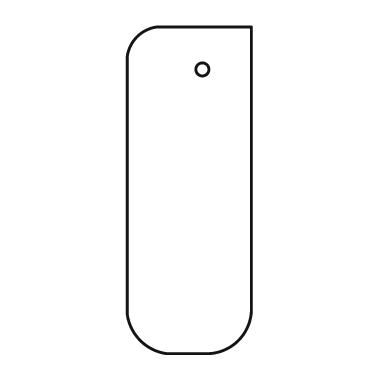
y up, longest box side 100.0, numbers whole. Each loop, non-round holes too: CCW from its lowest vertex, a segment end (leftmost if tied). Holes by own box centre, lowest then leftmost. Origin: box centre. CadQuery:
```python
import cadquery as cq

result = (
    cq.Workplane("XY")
    .moveTo(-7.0, -50.0)
    .lineTo(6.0, -50.0)
    .threePointArc((15.0, -46.0), (19.0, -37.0))
    .lineTo(19.0, 50.0)
    .lineTo(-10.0, 50.0)
    .threePointArc((-16.0, 47.0), (-19.0, 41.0))
    .lineTo(-19.0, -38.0)
    .threePointArc((-15.0, -46.0), (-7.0, -50.0))
    .close()
    .moveTo(4.0, 37.0)
    .circle(2.0)
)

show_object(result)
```